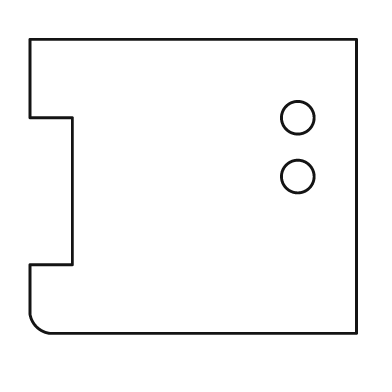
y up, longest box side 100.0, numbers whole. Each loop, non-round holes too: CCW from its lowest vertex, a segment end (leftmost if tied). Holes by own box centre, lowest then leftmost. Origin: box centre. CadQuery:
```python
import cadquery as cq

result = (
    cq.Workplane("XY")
    .moveTo(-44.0, -45.0)
    .lineTo(50.0, -45.0)
    .lineTo(50.0, 45.0)
    .lineTo(-50.0, 45.0)
    .lineTo(-50.0, 21.0)
    .lineTo(-37.0, 21.0)
    .lineTo(-37.0, -24.0)
    .lineTo(-50.0, -24.0)
    .lineTo(-50.0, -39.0)
    .threePointArc((-48.0, -43.0), (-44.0, -45.0))
    .close()
    .moveTo(32.0, 3.0)
    .circle(5.0)
    .moveTo(32.0, 21.0)
    .circle(5.0)
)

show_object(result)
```